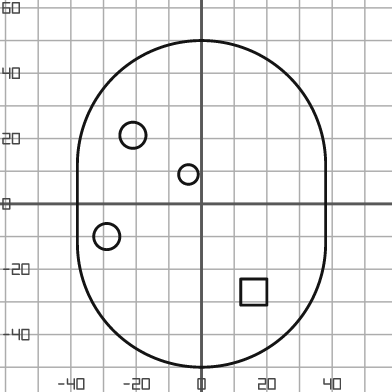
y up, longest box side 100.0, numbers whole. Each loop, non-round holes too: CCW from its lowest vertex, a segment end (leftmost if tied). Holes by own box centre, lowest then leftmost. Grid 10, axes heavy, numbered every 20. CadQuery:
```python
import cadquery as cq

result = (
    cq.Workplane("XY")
    .moveTo(-38.0, -12.0)
    .threePointArc((0.0, -50.0), (38.0, -12.0))
    .lineTo(38.0, 12.0)
    .threePointArc((0.0, 50.0), (-38.0, 12.0))
    .close()
    .moveTo(12.0, -31.0)
    .lineTo(20.0, -31.0)
    .lineTo(20.0, -23.0)
    .lineTo(12.0, -23.0)
    .close()
    .moveTo(-29.0, -10.0)
    .circle(4.0)
    .moveTo(-4.0, 9.0)
    .circle(3.0)
    .moveTo(-21.0, 21.0)
    .circle(4.0)
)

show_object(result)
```